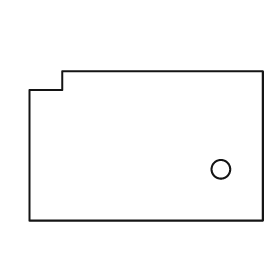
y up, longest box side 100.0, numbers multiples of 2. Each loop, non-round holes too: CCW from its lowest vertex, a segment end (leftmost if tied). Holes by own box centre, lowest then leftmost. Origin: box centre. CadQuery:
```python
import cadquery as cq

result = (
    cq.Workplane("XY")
    .moveTo(-50.0, -32.0)
    .lineTo(50.0, -32.0)
    .lineTo(50.0, 32.0)
    .lineTo(-36.0, 32.0)
    .lineTo(-36.0, 24.0)
    .lineTo(-50.0, 24.0)
    .close()
    .moveTo(32.0, -10.0)
    .circle(4.0)
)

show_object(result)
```